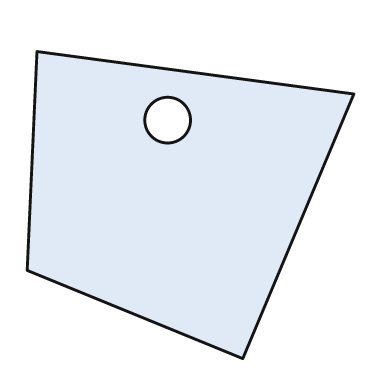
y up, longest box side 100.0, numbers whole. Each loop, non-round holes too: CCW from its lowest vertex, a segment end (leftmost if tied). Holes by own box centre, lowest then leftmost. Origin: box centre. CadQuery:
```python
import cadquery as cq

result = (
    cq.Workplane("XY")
    .moveTo(16.0, -47.0)
    .lineTo(50.0, 34.0)
    .lineTo(-47.0, 47.0)
    .lineTo(-50.0, -20.0)
    .close()
    .moveTo(-7.0, 26.0)
    .circle(7.0)
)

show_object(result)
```